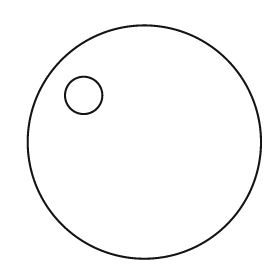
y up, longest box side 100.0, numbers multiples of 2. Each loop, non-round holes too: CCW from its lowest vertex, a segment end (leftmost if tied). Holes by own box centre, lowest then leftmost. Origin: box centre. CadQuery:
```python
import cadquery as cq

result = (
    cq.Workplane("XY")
    .moveTo(0.0, 0.0)
    .circle(50.0)
    .moveTo(-26.0, 20.0)
    .circle(8.0)
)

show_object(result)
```